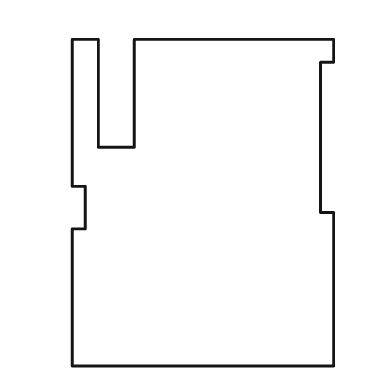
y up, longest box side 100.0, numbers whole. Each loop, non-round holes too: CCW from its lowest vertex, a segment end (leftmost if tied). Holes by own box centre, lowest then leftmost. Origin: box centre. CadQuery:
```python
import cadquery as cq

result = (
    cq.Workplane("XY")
    .moveTo(-40.0, -50.0)
    .lineTo(40.0, -50.0)
    .lineTo(40.0, -3.0)
    .lineTo(36.0, -3.0)
    .lineTo(36.0, 43.0)
    .lineTo(40.0, 43.0)
    .lineTo(40.0, 50.0)
    .lineTo(-21.0, 50.0)
    .lineTo(-21.0, 17.0)
    .lineTo(-32.0, 17.0)
    .lineTo(-32.0, 50.0)
    .lineTo(-40.0, 50.0)
    .lineTo(-40.0, 5.0)
    .lineTo(-36.0, 5.0)
    .lineTo(-36.0, -8.0)
    .lineTo(-40.0, -8.0)
    .close()
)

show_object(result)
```